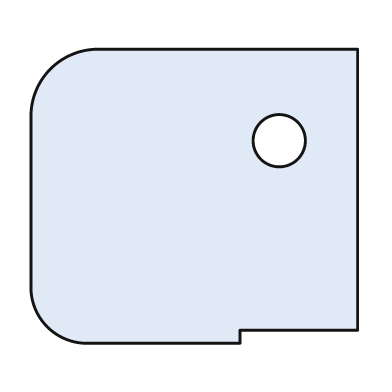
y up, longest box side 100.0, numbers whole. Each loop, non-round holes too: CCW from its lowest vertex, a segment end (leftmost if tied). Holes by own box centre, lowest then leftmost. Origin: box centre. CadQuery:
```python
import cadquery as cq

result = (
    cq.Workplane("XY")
    .moveTo(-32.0, -45.0)
    .lineTo(14.0, -45.0)
    .lineTo(14.0, -41.0)
    .lineTo(50.0, -41.0)
    .lineTo(50.0, 45.0)
    .lineTo(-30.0, 45.0)
    .threePointArc((-44.0, 39.0), (-50.0, 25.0))
    .lineTo(-50.0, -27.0)
    .threePointArc((-45.0, -40.0), (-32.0, -45.0))
    .close()
    .moveTo(26.0, 17.0)
    .circle(8.0)
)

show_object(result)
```